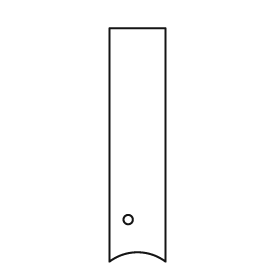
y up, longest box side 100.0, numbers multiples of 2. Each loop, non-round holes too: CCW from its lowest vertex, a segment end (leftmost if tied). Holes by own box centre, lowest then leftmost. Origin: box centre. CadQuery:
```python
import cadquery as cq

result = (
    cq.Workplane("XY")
    .moveTo(-12.0, -50.0)
    .threePointArc((0.0, -46.0), (12.0, -50.0))
    .lineTo(12.0, 50.0)
    .lineTo(-12.0, 50.0)
    .close()
    .moveTo(-4.0, -32.0)
    .circle(2.0)
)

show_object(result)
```